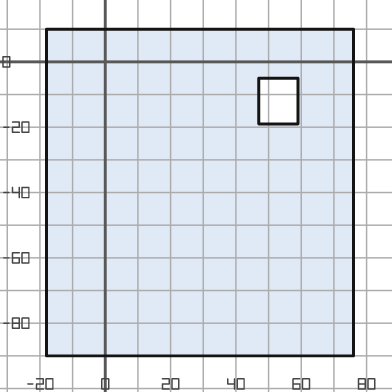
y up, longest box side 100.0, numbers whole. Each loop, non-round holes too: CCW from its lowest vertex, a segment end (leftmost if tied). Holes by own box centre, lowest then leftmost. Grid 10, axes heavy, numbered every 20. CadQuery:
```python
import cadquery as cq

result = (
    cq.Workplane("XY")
    .moveTo(-18.0, -90.0)
    .lineTo(76.0, -90.0)
    .lineTo(76.0, 10.0)
    .lineTo(-18.0, 10.0)
    .close()
    .moveTo(47.0, -19.0)
    .lineTo(59.0, -19.0)
    .lineTo(59.0, -5.0)
    .lineTo(47.0, -5.0)
    .close()
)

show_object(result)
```